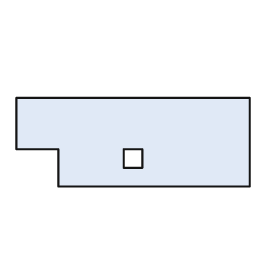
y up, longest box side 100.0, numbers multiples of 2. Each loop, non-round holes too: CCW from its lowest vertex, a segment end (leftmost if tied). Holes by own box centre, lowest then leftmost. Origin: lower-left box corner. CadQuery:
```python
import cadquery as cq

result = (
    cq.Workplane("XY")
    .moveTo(18.0, 0.0)
    .lineTo(100.0, 0.0)
    .lineTo(100.0, 38.0)
    .lineTo(0.0, 38.0)
    .lineTo(0.0, 16.0)
    .lineTo(18.0, 16.0)
    .close()
    .moveTo(46.0, 8.0)
    .lineTo(54.0, 8.0)
    .lineTo(54.0, 16.0)
    .lineTo(46.0, 16.0)
    .close()
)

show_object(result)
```